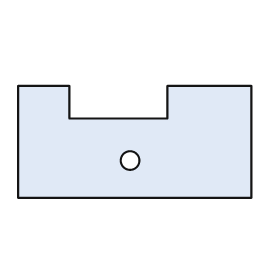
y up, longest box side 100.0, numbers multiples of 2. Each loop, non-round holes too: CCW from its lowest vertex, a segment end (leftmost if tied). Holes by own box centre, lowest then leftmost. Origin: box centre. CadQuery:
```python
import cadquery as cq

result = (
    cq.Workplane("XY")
    .moveTo(-50.0, -24.0)
    .lineTo(50.0, -24.0)
    .lineTo(50.0, 24.0)
    .lineTo(14.0, 24.0)
    .lineTo(14.0, 10.0)
    .lineTo(-28.0, 10.0)
    .lineTo(-28.0, 24.0)
    .lineTo(-50.0, 24.0)
    .close()
    .moveTo(-2.0, -8.0)
    .circle(4.0)
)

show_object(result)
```